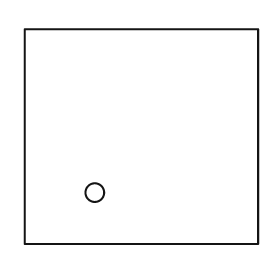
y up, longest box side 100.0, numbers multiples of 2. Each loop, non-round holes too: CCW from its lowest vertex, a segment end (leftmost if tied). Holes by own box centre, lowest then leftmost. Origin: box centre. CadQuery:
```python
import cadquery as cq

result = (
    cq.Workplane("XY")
    .moveTo(-50.0, -46.0)
    .lineTo(50.0, -46.0)
    .lineTo(50.0, 46.0)
    .lineTo(-50.0, 46.0)
    .close()
    .moveTo(-20.0, -24.0)
    .circle(4.0)
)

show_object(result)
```